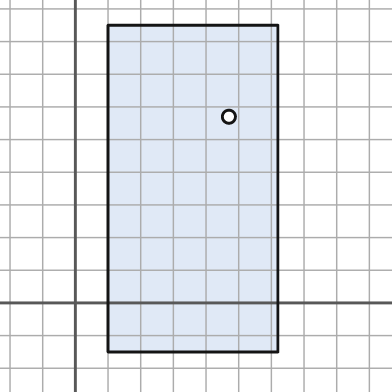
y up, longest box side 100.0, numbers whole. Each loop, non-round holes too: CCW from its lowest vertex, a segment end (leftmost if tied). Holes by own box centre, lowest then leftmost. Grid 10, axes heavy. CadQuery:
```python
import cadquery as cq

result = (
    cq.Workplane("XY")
    .moveTo(10.0, -15.0)
    .lineTo(62.0, -15.0)
    .lineTo(62.0, 85.0)
    .lineTo(10.0, 85.0)
    .close()
    .moveTo(47.0, 57.0)
    .circle(2.0)
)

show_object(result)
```